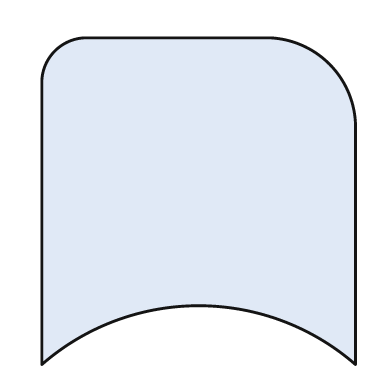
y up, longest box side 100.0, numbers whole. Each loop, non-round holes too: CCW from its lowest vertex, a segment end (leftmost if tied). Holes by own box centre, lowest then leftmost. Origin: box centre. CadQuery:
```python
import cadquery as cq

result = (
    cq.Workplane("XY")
    .moveTo(-48.0, -50.0)
    .threePointArc((0.0, -32.0), (48.0, -50.0))
    .lineTo(48.0, 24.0)
    .threePointArc((40.0, 42.0), (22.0, 50.0))
    .lineTo(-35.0, 50.0)
    .threePointArc((-44.0, 46.0), (-48.0, 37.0))
    .close()
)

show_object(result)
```